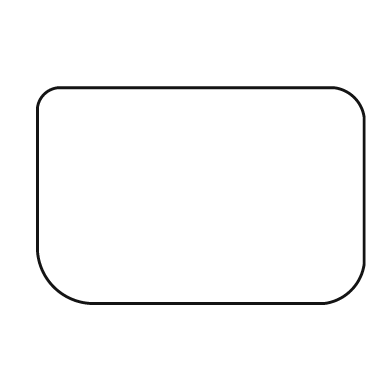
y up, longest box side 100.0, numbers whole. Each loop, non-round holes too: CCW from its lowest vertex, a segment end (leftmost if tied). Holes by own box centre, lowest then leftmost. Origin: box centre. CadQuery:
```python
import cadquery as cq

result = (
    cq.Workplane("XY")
    .moveTo(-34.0, -33.0)
    .lineTo(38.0, -33.0)
    .threePointArc((46.0, -29.0), (50.0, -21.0))
    .lineTo(50.0, 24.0)
    .threePointArc((47.0, 30.0), (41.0, 33.0))
    .lineTo(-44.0, 33.0)
    .threePointArc((-48.0, 31.0), (-50.0, 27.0))
    .lineTo(-50.0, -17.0)
    .threePointArc((-45.0, -28.0), (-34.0, -33.0))
    .close()
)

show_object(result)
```